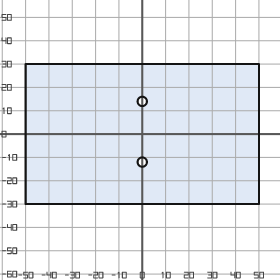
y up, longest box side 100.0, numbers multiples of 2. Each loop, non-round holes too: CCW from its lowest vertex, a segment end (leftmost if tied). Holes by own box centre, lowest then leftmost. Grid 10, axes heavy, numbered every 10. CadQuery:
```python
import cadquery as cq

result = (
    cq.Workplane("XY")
    .moveTo(-50.0, -30.0)
    .lineTo(50.0, -30.0)
    .lineTo(50.0, 30.0)
    .lineTo(-50.0, 30.0)
    .close()
    .moveTo(0.0, -12.0)
    .circle(2.0)
    .moveTo(0.0, 14.0)
    .circle(2.0)
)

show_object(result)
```